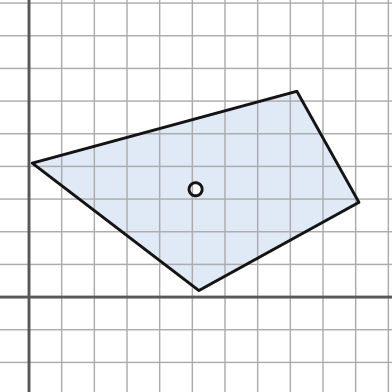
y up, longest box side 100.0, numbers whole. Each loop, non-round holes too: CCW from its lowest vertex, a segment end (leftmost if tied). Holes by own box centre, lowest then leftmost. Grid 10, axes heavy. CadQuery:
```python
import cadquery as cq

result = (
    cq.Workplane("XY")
    .moveTo(52.0, 2.0)
    .lineTo(101.0, 29.0)
    .lineTo(82.0, 63.0)
    .lineTo(1.0, 41.0)
    .close()
    .moveTo(51.0, 33.0)
    .circle(2.0)
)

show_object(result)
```